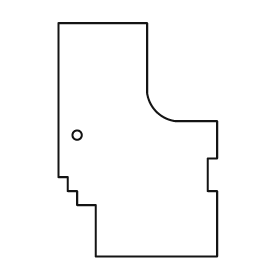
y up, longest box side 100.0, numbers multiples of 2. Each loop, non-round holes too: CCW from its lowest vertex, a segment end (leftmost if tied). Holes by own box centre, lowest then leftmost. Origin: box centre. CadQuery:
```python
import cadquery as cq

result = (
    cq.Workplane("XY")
    .moveTo(-18.0, -50.0)
    .lineTo(34.0, -50.0)
    .lineTo(34.0, -22.0)
    .lineTo(30.0, -22.0)
    .lineTo(30.0, -8.0)
    .lineTo(34.0, -8.0)
    .lineTo(34.0, 8.0)
    .lineTo(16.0, 8.0)
    .threePointArc((8.0, 12.0), (4.0, 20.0))
    .lineTo(4.0, 50.0)
    .lineTo(-34.0, 50.0)
    .lineTo(-34.0, -16.0)
    .lineTo(-30.0, -16.0)
    .lineTo(-30.0, -22.0)
    .lineTo(-26.0, -22.0)
    .lineTo(-26.0, -28.0)
    .lineTo(-18.0, -28.0)
    .close()
    .moveTo(-26.0, 2.0)
    .circle(2.0)
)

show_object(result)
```